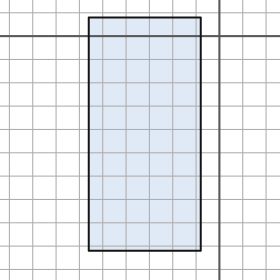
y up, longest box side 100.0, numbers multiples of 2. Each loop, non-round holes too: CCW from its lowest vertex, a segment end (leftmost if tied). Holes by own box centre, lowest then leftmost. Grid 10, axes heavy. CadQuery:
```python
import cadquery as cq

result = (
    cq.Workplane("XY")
    .moveTo(-56.0, -92.0)
    .lineTo(-8.0, -92.0)
    .lineTo(-8.0, 8.0)
    .lineTo(-56.0, 8.0)
    .close()
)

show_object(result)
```